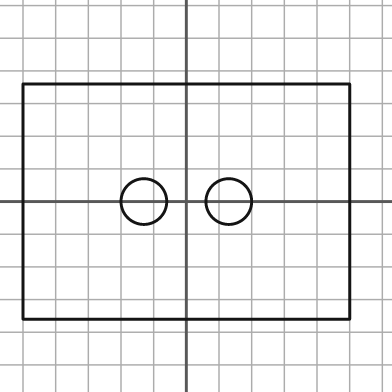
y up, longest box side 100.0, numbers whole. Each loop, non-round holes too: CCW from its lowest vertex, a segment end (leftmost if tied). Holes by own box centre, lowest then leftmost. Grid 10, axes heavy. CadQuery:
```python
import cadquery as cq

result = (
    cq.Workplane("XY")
    .moveTo(-50.0, -36.0)
    .lineTo(50.0, -36.0)
    .lineTo(50.0, 36.0)
    .lineTo(-50.0, 36.0)
    .close()
    .moveTo(-13.0, 0.0)
    .circle(7.0)
    .moveTo(13.0, 0.0)
    .circle(7.0)
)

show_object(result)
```